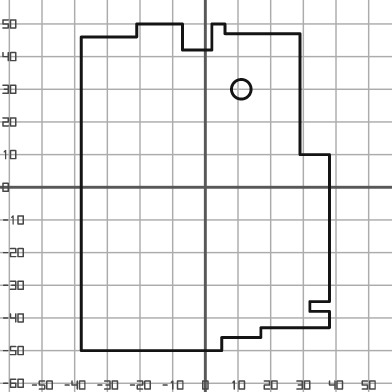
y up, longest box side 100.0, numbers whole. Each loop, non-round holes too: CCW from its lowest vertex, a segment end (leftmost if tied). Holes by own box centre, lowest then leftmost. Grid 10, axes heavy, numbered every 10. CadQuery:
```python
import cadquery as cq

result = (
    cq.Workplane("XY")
    .moveTo(-38.0, -50.0)
    .lineTo(5.0, -50.0)
    .lineTo(5.0, -46.0)
    .lineTo(17.0, -46.0)
    .lineTo(17.0, -43.0)
    .lineTo(38.0, -43.0)
    .lineTo(38.0, -38.0)
    .lineTo(32.0, -38.0)
    .lineTo(32.0, -35.0)
    .lineTo(38.0, -35.0)
    .lineTo(38.0, 10.0)
    .lineTo(29.0, 10.0)
    .lineTo(29.0, 47.0)
    .lineTo(6.0, 47.0)
    .lineTo(6.0, 50.0)
    .lineTo(2.0, 50.0)
    .lineTo(2.0, 42.0)
    .lineTo(-7.0, 42.0)
    .lineTo(-7.0, 50.0)
    .lineTo(-21.0, 50.0)
    .lineTo(-21.0, 46.0)
    .lineTo(-38.0, 46.0)
    .close()
    .moveTo(11.0, 30.0)
    .circle(3.0)
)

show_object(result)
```